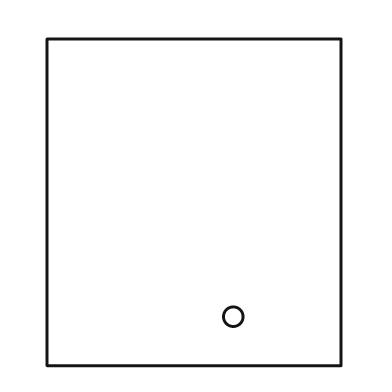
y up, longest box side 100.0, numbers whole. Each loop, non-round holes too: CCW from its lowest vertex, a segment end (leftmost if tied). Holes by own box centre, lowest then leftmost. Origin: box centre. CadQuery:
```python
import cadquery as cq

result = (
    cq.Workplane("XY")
    .moveTo(-45.0, -50.0)
    .lineTo(45.0, -50.0)
    .lineTo(45.0, 50.0)
    .lineTo(-45.0, 50.0)
    .close()
    .moveTo(12.0, -35.0)
    .circle(3.0)
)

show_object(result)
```